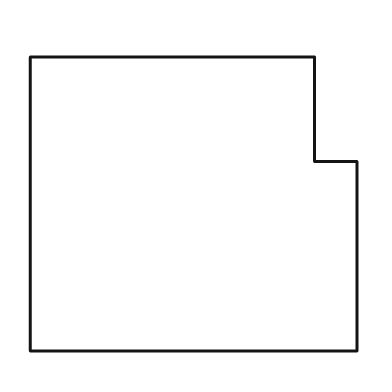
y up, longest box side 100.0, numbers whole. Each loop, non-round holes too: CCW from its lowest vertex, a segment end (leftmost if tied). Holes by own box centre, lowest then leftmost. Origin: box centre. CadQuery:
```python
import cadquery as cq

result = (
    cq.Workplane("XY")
    .moveTo(-50.0, -45.0)
    .lineTo(50.0, -45.0)
    .lineTo(50.0, 13.0)
    .lineTo(37.0, 13.0)
    .lineTo(37.0, 45.0)
    .lineTo(-50.0, 45.0)
    .close()
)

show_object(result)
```